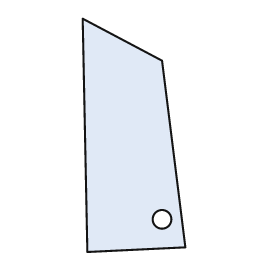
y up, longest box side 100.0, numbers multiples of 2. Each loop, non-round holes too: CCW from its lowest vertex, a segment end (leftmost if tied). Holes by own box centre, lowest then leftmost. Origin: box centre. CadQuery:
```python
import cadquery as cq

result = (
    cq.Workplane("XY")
    .moveTo(-20.0, -50.0)
    .lineTo(22.0, -48.0)
    .lineTo(12.0, 32.0)
    .lineTo(-22.0, 50.0)
    .close()
    .moveTo(12.0, -36.0)
    .circle(4.0)
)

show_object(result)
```